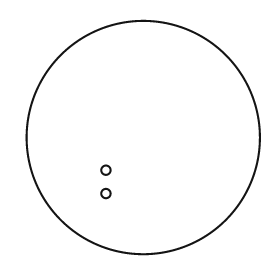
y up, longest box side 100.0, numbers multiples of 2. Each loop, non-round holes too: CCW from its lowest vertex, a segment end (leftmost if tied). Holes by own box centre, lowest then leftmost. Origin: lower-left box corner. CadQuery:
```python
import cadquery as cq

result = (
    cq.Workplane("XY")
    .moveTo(50.0, 50.0)
    .circle(50.0)
    .moveTo(34.0, 26.0)
    .circle(2.0)
    .moveTo(34.0, 36.0)
    .circle(2.0)
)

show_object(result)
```